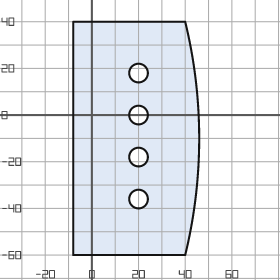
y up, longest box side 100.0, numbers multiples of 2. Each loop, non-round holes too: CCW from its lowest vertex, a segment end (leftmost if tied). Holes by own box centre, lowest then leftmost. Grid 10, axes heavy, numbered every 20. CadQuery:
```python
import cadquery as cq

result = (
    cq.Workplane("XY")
    .moveTo(-8.0, -60.0)
    .lineTo(40.0, -60.0)
    .threePointArc((46.0, -10.0), (40.0, 40.0))
    .lineTo(-8.0, 40.0)
    .close()
    .moveTo(20.0, -36.0)
    .circle(4.0)
    .moveTo(20.0, -18.0)
    .circle(4.0)
    .moveTo(20.0, 0.0)
    .circle(4.0)
    .moveTo(20.0, 18.0)
    .circle(4.0)
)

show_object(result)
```